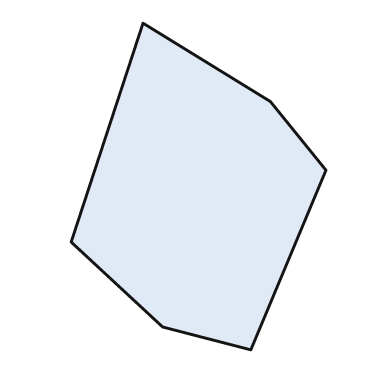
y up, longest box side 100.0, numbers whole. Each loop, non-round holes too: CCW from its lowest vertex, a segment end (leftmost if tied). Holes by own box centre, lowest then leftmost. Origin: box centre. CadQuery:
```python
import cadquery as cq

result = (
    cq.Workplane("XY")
    .moveTo(16.0, -50.0)
    .lineTo(39.0, 5.0)
    .lineTo(22.0, 26.0)
    .lineTo(-17.0, 50.0)
    .lineTo(-39.0, -17.0)
    .lineTo(-11.0, -43.0)
    .close()
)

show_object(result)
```